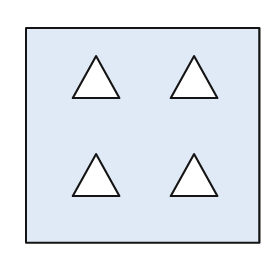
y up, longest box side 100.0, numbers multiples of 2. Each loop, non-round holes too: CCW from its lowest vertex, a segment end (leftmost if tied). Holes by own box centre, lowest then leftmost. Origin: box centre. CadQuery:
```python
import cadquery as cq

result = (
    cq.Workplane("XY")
    .moveTo(-50.0, -46.0)
    .lineTo(50.0, -46.0)
    .lineTo(50.0, 46.0)
    .lineTo(-50.0, 46.0)
    .close()
    .moveTo(-30.0, -26.0)
    .lineTo(-10.0, -26.0)
    .lineTo(-20.0, -8.0)
    .close()
    .moveTo(12.0, -26.0)
    .lineTo(32.0, -26.0)
    .lineTo(22.0, -8.0)
    .close()
    .moveTo(-30.0, 16.0)
    .lineTo(-10.0, 16.0)
    .lineTo(-20.0, 34.0)
    .close()
    .moveTo(12.0, 16.0)
    .lineTo(32.0, 16.0)
    .lineTo(22.0, 34.0)
    .close()
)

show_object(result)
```